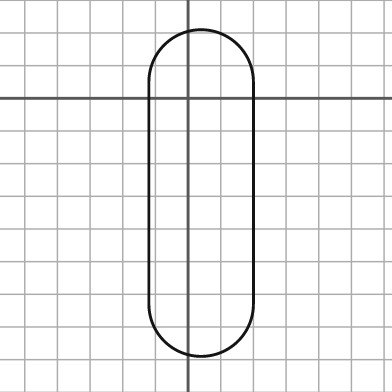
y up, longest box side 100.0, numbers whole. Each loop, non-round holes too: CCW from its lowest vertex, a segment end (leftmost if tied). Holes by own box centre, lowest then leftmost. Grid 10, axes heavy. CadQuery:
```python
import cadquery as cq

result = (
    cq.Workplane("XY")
    .moveTo(-12.0, -63.0)
    .threePointArc((4.0, -79.0), (20.0, -63.0))
    .lineTo(20.0, 5.0)
    .threePointArc((4.0, 21.0), (-12.0, 5.0))
    .close()
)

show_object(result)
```